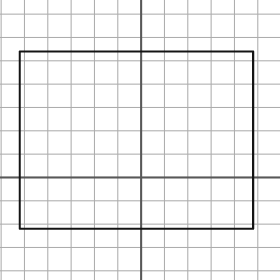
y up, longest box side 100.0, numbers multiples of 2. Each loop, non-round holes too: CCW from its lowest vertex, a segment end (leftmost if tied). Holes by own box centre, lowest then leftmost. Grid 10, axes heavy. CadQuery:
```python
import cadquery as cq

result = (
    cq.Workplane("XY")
    .moveTo(-52.0, -22.0)
    .lineTo(48.0, -22.0)
    .lineTo(48.0, 54.0)
    .lineTo(-52.0, 54.0)
    .close()
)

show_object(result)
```